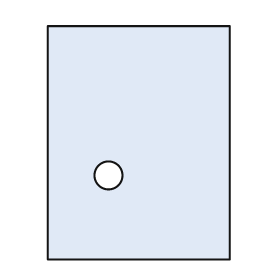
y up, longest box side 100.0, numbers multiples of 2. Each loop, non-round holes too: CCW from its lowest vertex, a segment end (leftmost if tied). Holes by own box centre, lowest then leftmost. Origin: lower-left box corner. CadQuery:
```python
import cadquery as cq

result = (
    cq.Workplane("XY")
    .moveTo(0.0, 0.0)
    .lineTo(78.0, 0.0)
    .lineTo(78.0, 100.0)
    .lineTo(0.0, 100.0)
    .close()
    .moveTo(26.0, 36.0)
    .circle(6.0)
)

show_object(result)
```